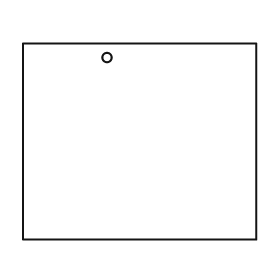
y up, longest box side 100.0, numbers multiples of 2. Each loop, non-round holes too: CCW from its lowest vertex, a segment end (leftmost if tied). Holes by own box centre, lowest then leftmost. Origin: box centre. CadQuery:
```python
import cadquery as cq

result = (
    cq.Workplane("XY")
    .moveTo(-50.0, -42.0)
    .lineTo(50.0, -42.0)
    .lineTo(50.0, 42.0)
    .lineTo(-50.0, 42.0)
    .close()
    .moveTo(-14.0, 36.0)
    .circle(2.0)
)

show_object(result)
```